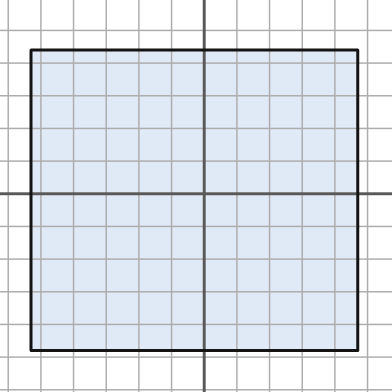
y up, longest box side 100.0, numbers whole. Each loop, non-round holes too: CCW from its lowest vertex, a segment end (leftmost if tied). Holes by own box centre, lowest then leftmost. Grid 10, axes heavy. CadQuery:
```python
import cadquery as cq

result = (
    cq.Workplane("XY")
    .moveTo(-53.0, -48.0)
    .lineTo(47.0, -48.0)
    .lineTo(47.0, 44.0)
    .lineTo(-53.0, 44.0)
    .close()
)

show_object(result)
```